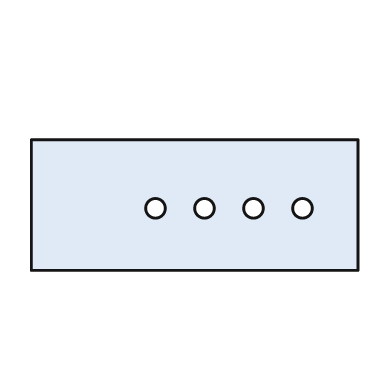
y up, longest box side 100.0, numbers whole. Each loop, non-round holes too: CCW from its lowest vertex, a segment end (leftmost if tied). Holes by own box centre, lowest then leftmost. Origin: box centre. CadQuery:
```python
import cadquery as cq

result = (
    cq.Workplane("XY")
    .moveTo(-50.0, -20.0)
    .lineTo(50.0, -20.0)
    .lineTo(50.0, 20.0)
    .lineTo(-50.0, 20.0)
    .close()
    .moveTo(-12.0, -1.0)
    .circle(3.0)
    .moveTo(3.0, -1.0)
    .circle(3.0)
    .moveTo(18.0, -1.0)
    .circle(3.0)
    .moveTo(33.0, -1.0)
    .circle(3.0)
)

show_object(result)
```